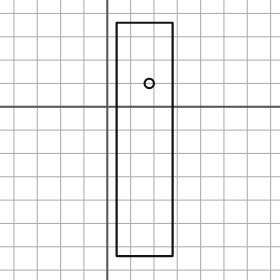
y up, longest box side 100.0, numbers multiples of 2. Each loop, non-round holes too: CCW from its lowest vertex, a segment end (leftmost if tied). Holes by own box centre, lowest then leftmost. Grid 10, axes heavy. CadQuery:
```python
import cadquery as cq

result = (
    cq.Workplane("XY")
    .moveTo(4.0, -64.0)
    .lineTo(28.0, -64.0)
    .lineTo(28.0, 36.0)
    .lineTo(4.0, 36.0)
    .close()
    .moveTo(18.0, 10.0)
    .circle(2.0)
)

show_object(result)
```